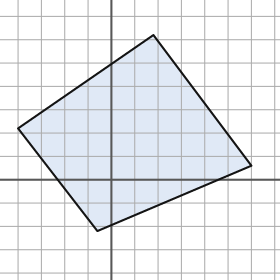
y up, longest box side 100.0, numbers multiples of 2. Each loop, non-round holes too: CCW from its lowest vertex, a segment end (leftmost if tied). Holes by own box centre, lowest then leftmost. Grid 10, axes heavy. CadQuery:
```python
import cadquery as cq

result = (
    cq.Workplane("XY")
    .moveTo(-6.0, -22.0)
    .lineTo(60.0, 6.0)
    .lineTo(18.0, 62.0)
    .lineTo(-40.0, 22.0)
    .close()
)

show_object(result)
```